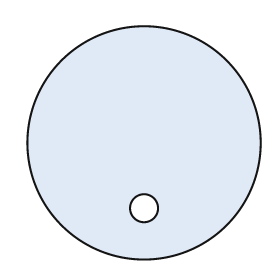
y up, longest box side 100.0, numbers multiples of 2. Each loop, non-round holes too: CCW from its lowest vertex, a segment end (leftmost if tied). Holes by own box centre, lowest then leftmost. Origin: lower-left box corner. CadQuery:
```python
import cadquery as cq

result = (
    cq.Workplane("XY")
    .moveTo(50.0, 50.0)
    .circle(50.0)
    .moveTo(50.0, 22.0)
    .circle(6.0)
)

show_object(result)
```